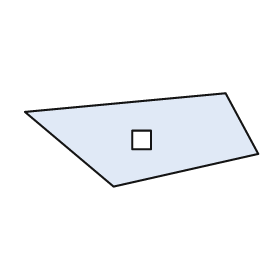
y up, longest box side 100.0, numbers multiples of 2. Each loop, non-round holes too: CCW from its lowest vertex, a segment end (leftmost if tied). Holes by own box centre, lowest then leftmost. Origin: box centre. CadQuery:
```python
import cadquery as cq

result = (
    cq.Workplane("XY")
    .moveTo(-12.0, -20.0)
    .lineTo(50.0, -6.0)
    .lineTo(36.0, 20.0)
    .lineTo(-50.0, 12.0)
    .close()
    .moveTo(-4.0, -4.0)
    .lineTo(4.0, -4.0)
    .lineTo(4.0, 4.0)
    .lineTo(-4.0, 4.0)
    .close()
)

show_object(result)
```